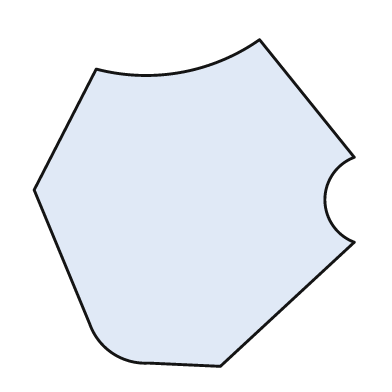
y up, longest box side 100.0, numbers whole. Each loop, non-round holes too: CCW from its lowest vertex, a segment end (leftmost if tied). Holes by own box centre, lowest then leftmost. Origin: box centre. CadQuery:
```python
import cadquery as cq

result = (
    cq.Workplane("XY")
    .moveTo(8.0, -50.0)
    .lineTo(49.0, -12.0)
    .threePointArc((40.0, 1.0), (49.0, 14.0))
    .lineTo(20.0, 50.0)
    .threePointArc((-4.0, 40.0), (-30.0, 41.0))
    .lineTo(-49.0, 4.0)
    .lineTo(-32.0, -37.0)
    .threePointArc((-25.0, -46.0), (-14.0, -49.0))
    .close()
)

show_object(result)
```